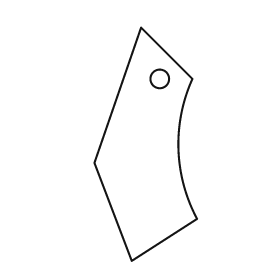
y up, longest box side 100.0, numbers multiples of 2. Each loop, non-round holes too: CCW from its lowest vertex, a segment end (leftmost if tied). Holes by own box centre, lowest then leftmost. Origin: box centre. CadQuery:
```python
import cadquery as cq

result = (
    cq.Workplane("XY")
    .moveTo(-6.0, -50.0)
    .lineTo(22.0, -32.0)
    .threePointArc((14.0, -2.0), (20.0, 28.0))
    .lineTo(-2.0, 50.0)
    .lineTo(-22.0, -8.0)
    .close()
    .moveTo(6.0, 28.0)
    .circle(4.0)
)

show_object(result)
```